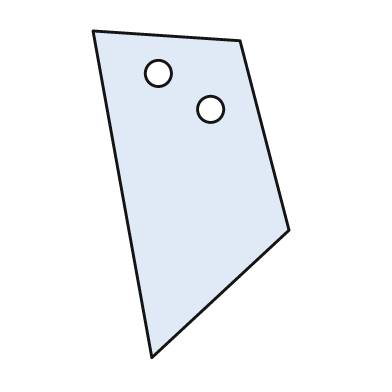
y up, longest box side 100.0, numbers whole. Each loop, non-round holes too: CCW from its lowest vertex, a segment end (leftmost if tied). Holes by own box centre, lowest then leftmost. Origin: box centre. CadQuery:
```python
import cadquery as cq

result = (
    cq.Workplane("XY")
    .moveTo(-12.0, -50.0)
    .lineTo(30.0, -11.0)
    .lineTo(15.0, 47.0)
    .lineTo(-30.0, 50.0)
    .close()
    .moveTo(6.0, 26.0)
    .circle(4.0)
    .moveTo(-10.0, 37.0)
    .circle(4.0)
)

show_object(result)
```